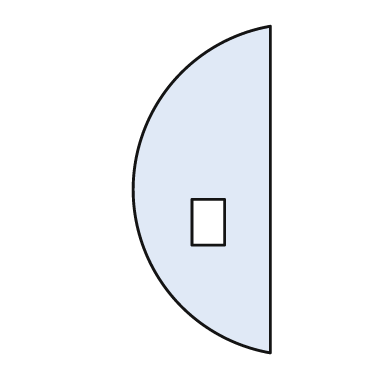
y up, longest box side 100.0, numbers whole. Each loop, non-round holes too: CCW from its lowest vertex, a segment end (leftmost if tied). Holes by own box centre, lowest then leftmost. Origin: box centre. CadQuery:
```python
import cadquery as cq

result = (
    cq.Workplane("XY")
    .moveTo(21.0, -50.0)
    .lineTo(21.0, 50.0)
    .threePointArc((-21.0, 0.0), (21.0, -50.0))
    .close()
    .moveTo(-3.0, -17.0)
    .lineTo(7.0, -17.0)
    .lineTo(7.0, -3.0)
    .lineTo(-3.0, -3.0)
    .close()
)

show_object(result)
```